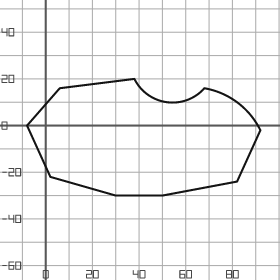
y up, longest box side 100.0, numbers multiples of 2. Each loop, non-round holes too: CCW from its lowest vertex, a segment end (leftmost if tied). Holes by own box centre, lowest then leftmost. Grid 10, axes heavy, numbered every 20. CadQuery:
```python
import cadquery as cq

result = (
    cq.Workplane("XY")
    .moveTo(30.0, -30.0)
    .lineTo(50.0, -30.0)
    .lineTo(82.0, -24.0)
    .lineTo(92.0, -2.0)
    .threePointArc((82.0, 10.0), (68.0, 16.0))
    .threePointArc((52.0, 10.0), (38.0, 20.0))
    .lineTo(6.0, 16.0)
    .lineTo(-8.0, 0.0)
    .lineTo(2.0, -22.0)
    .close()
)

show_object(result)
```